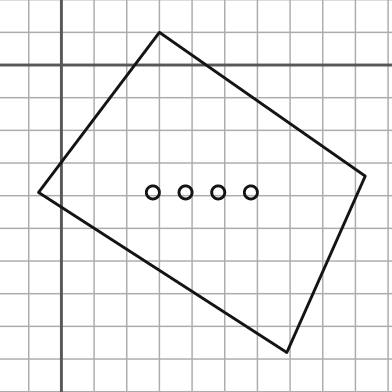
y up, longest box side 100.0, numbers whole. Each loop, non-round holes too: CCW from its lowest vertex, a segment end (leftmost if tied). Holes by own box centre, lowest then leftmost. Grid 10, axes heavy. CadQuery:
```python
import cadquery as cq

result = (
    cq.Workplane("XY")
    .moveTo(69.0, -88.0)
    .lineTo(93.0, -34.0)
    .lineTo(30.0, 10.0)
    .lineTo(-7.0, -39.0)
    .close()
    .moveTo(28.0, -39.0)
    .circle(2.0)
    .moveTo(38.0, -39.0)
    .circle(2.0)
    .moveTo(48.0, -39.0)
    .circle(2.0)
    .moveTo(58.0, -39.0)
    .circle(2.0)
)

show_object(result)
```